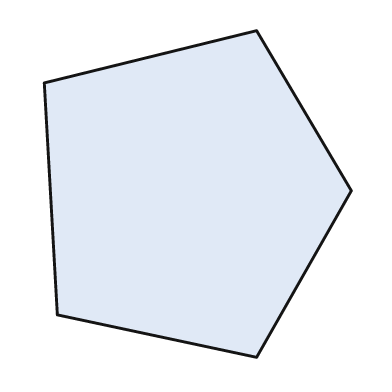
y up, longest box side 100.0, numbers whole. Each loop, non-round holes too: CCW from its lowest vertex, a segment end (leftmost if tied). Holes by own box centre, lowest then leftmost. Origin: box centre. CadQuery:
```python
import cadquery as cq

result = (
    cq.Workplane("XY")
    .moveTo(18.0, -50.0)
    .lineTo(47.0, 1.0)
    .lineTo(18.0, 50.0)
    .lineTo(-47.0, 34.0)
    .lineTo(-43.0, -37.0)
    .close()
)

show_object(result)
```